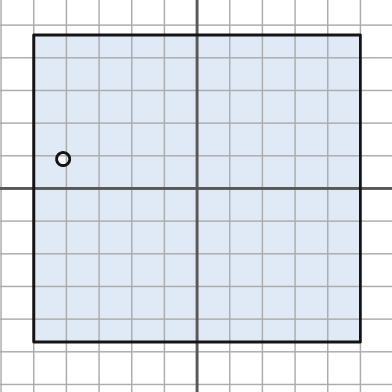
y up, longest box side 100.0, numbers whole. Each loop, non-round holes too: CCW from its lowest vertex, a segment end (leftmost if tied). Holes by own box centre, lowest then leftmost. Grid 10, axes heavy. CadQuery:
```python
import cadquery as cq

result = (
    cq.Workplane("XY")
    .moveTo(-50.0, -47.0)
    .lineTo(50.0, -47.0)
    .lineTo(50.0, 47.0)
    .lineTo(-50.0, 47.0)
    .close()
    .moveTo(-41.0, 9.0)
    .circle(2.0)
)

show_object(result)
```